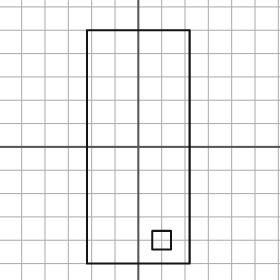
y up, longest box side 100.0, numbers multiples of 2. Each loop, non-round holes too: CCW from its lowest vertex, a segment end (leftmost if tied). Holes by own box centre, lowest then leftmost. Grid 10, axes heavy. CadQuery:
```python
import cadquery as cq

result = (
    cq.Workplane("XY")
    .moveTo(-22.0, -50.0)
    .lineTo(22.0, -50.0)
    .lineTo(22.0, 50.0)
    .lineTo(-22.0, 50.0)
    .close()
    .moveTo(6.0, -44.0)
    .lineTo(14.0, -44.0)
    .lineTo(14.0, -36.0)
    .lineTo(6.0, -36.0)
    .close()
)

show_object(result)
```